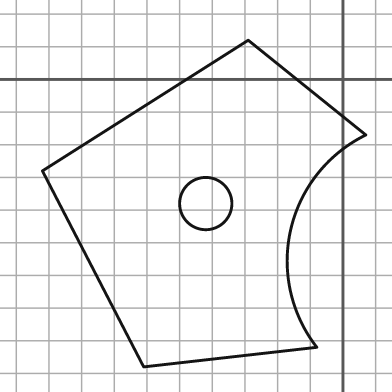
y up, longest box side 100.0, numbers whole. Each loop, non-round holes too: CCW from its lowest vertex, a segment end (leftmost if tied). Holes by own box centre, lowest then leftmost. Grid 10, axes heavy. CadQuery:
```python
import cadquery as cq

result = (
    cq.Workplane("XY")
    .moveTo(-61.0, -88.0)
    .lineTo(-8.0, -82.0)
    .threePointArc((-16.0, -46.0), (7.0, -17.0))
    .lineTo(-29.0, 12.0)
    .lineTo(-92.0, -28.0)
    .close()
    .moveTo(-42.0, -38.0)
    .circle(8.0)
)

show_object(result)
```